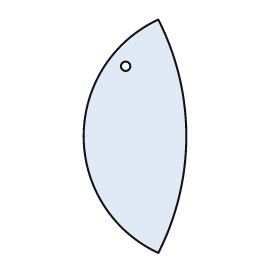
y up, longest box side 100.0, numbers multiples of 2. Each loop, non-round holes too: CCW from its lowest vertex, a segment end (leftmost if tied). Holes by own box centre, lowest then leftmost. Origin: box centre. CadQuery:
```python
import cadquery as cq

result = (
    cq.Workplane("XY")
    .moveTo(10.0, -50.0)
    .threePointArc((22.0, 0.0), (10.0, 50.0))
    .threePointArc((-22.0, 0.0), (10.0, -50.0))
    .close()
    .moveTo(-4.0, 30.0)
    .circle(2.0)
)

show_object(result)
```